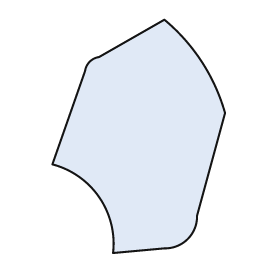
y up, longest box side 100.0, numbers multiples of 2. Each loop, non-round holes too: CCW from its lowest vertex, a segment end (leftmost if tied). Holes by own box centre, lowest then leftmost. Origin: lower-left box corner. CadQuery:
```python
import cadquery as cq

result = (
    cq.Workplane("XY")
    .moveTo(26.0, 0.0)
    .lineTo(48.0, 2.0)
    .threePointArc((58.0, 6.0), (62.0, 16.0))
    .lineTo(74.0, 60.0)
    .threePointArc((64.0, 82.0), (48.0, 100.0))
    .lineTo(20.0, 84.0)
    .threePointArc((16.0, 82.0), (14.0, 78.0))
    .lineTo(0.0, 38.0)
    .threePointArc((20.0, 24.0), (26.0, 0.0))
    .close()
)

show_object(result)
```